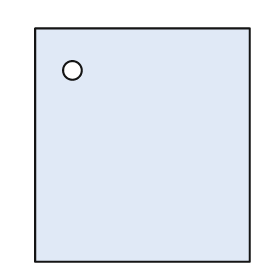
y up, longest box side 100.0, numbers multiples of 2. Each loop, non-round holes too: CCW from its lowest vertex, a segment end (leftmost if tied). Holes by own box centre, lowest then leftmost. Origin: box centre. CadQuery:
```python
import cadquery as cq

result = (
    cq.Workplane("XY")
    .moveTo(-46.0, -50.0)
    .lineTo(46.0, -50.0)
    .lineTo(46.0, 50.0)
    .lineTo(-46.0, 50.0)
    .close()
    .moveTo(-30.0, 32.0)
    .circle(4.0)
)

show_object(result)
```